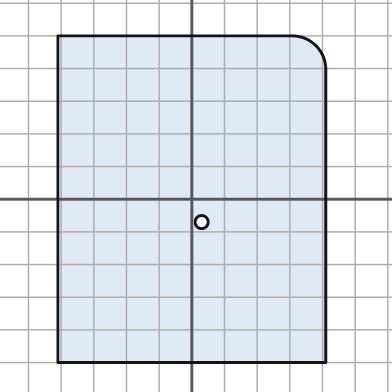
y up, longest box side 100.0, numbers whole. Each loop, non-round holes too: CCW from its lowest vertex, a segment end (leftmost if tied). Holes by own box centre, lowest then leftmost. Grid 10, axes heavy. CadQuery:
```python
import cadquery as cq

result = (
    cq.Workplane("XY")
    .moveTo(-41.0, -50.0)
    .lineTo(41.0, -50.0)
    .lineTo(41.0, 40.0)
    .threePointArc((38.0, 47.0), (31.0, 50.0))
    .lineTo(-41.0, 50.0)
    .close()
    .moveTo(3.0, -7.0)
    .circle(2.0)
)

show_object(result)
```